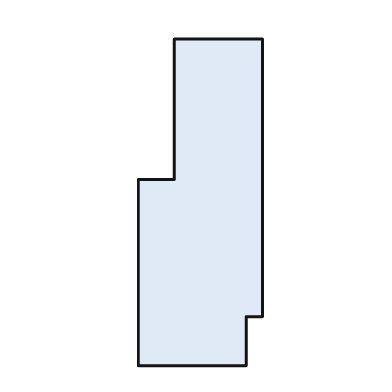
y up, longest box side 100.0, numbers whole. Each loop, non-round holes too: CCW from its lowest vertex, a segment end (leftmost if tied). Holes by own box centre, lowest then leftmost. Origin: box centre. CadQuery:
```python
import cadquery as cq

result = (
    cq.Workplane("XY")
    .moveTo(-19.0, -50.0)
    .lineTo(14.0, -50.0)
    .lineTo(14.0, -35.0)
    .lineTo(19.0, -35.0)
    .lineTo(19.0, 50.0)
    .lineTo(-8.0, 50.0)
    .lineTo(-8.0, 7.0)
    .lineTo(-19.0, 7.0)
    .close()
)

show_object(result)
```